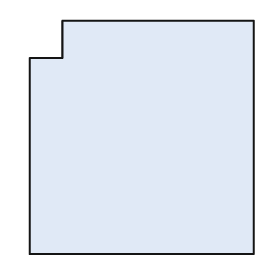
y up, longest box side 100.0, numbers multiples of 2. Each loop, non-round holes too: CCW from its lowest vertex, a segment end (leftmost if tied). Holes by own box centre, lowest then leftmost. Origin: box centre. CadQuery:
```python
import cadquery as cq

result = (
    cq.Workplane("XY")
    .moveTo(-48.0, -50.0)
    .lineTo(48.0, -50.0)
    .lineTo(48.0, 50.0)
    .lineTo(-34.0, 50.0)
    .lineTo(-34.0, 34.0)
    .lineTo(-48.0, 34.0)
    .close()
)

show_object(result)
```